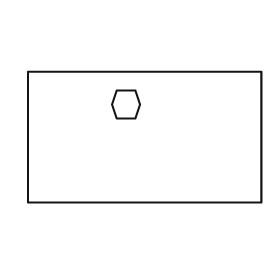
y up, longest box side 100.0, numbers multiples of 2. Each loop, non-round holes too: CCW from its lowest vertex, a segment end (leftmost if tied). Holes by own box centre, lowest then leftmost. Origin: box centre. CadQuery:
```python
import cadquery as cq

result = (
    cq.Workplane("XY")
    .moveTo(-50.0, -28.0)
    .lineTo(50.0, -28.0)
    .lineTo(50.0, 28.0)
    .lineTo(-50.0, 28.0)
    .close()
    .moveTo(-12.0, 8.0)
    .lineTo(-4.0, 8.0)
    .lineTo(-2.0, 14.0)
    .lineTo(-4.0, 20.0)
    .lineTo(-12.0, 20.0)
    .lineTo(-14.0, 14.0)
    .close()
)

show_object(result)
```